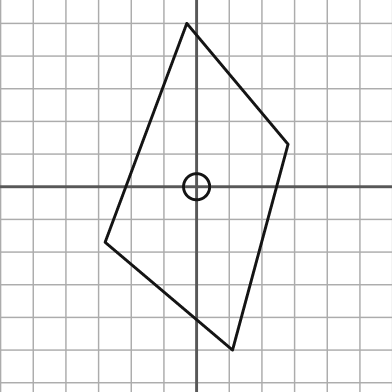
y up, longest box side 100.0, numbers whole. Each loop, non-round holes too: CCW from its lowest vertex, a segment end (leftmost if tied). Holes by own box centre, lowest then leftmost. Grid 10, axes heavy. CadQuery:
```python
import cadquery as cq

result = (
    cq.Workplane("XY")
    .moveTo(11.0, -50.0)
    .lineTo(28.0, 13.0)
    .lineTo(-3.0, 50.0)
    .lineTo(-28.0, -17.0)
    .close()
    .moveTo(0.0, 0.0)
    .circle(4.0)
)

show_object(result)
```